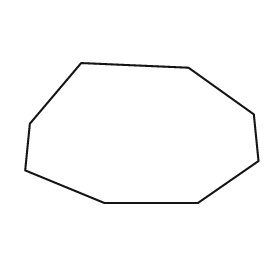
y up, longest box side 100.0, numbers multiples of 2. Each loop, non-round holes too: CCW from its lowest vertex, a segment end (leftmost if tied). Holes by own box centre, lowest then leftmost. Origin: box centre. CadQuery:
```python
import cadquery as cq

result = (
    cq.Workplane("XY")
    .moveTo(-16.0, -30.0)
    .lineTo(24.0, -30.0)
    .lineTo(50.0, -12.0)
    .lineTo(48.0, 8.0)
    .lineTo(20.0, 28.0)
    .lineTo(-26.0, 30.0)
    .lineTo(-48.0, 4.0)
    .lineTo(-50.0, -16.0)
    .close()
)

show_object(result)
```